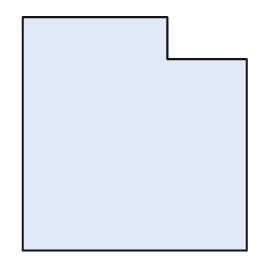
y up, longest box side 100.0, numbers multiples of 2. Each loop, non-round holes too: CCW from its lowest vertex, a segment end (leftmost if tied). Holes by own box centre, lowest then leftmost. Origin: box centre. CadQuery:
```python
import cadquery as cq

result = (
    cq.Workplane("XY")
    .moveTo(-48.0, -50.0)
    .lineTo(48.0, -50.0)
    .lineTo(48.0, 32.0)
    .lineTo(14.0, 32.0)
    .lineTo(14.0, 50.0)
    .lineTo(-48.0, 50.0)
    .close()
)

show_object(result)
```